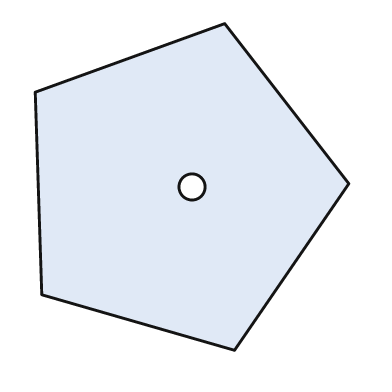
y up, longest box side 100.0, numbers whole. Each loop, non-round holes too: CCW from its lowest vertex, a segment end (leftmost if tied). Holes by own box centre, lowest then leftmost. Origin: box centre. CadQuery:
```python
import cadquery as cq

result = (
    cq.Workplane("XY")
    .moveTo(13.0, -50.0)
    .lineTo(48.0, 1.0)
    .lineTo(10.0, 50.0)
    .lineTo(-48.0, 29.0)
    .lineTo(-46.0, -33.0)
    .close()
    .moveTo(0.0, 0.0)
    .circle(4.0)
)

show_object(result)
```